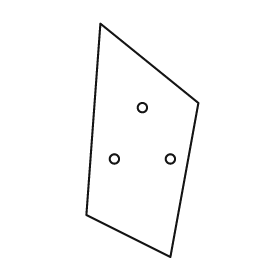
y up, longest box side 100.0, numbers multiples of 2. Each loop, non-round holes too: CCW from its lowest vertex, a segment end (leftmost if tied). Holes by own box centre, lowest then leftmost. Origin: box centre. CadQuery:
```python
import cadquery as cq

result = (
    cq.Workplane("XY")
    .moveTo(12.0, -50.0)
    .lineTo(24.0, 16.0)
    .lineTo(-18.0, 50.0)
    .lineTo(-24.0, -32.0)
    .close()
    .moveTo(-12.0, -8.0)
    .circle(2.0)
    .moveTo(12.0, -8.0)
    .circle(2.0)
    .moveTo(0.0, 14.0)
    .circle(2.0)
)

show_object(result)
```